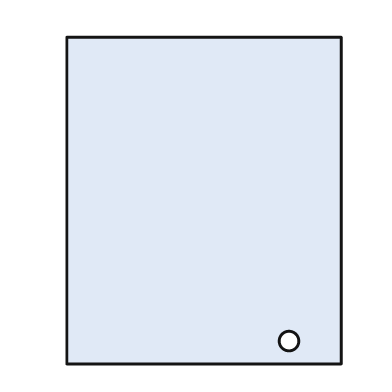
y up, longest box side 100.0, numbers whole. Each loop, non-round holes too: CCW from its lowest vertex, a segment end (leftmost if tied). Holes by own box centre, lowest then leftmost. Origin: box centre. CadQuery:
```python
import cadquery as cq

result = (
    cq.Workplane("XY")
    .moveTo(-42.0, -50.0)
    .lineTo(42.0, -50.0)
    .lineTo(42.0, 50.0)
    .lineTo(-42.0, 50.0)
    .close()
    .moveTo(26.0, -43.0)
    .circle(3.0)
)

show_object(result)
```